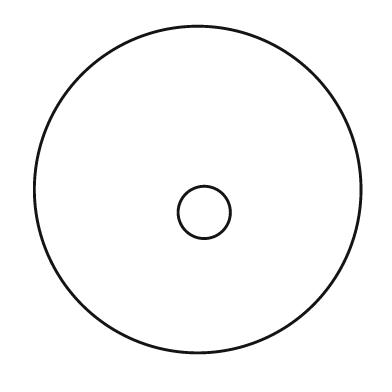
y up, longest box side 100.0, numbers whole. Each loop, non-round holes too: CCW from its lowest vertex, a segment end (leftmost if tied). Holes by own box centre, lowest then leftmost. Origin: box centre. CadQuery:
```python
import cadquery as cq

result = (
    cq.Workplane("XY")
    .moveTo(0.0, 0.0)
    .circle(50.0)
    .moveTo(2.0, -7.0)
    .circle(8.0)
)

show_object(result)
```